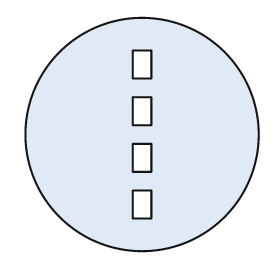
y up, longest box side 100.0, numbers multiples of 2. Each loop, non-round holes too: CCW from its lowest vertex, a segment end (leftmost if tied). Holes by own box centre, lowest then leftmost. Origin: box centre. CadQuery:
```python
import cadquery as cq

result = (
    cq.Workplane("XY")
    .moveTo(0.0, 0.0)
    .circle(50.0)
    .moveTo(-4.0, -36.0)
    .lineTo(4.0, -36.0)
    .lineTo(4.0, -24.0)
    .lineTo(-4.0, -24.0)
    .close()
    .moveTo(-4.0, -16.0)
    .lineTo(4.0, -16.0)
    .lineTo(4.0, -4.0)
    .lineTo(-4.0, -4.0)
    .close()
    .moveTo(-4.0, 4.0)
    .lineTo(4.0, 4.0)
    .lineTo(4.0, 16.0)
    .lineTo(-4.0, 16.0)
    .close()
    .moveTo(-4.0, 24.0)
    .lineTo(4.0, 24.0)
    .lineTo(4.0, 36.0)
    .lineTo(-4.0, 36.0)
    .close()
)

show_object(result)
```